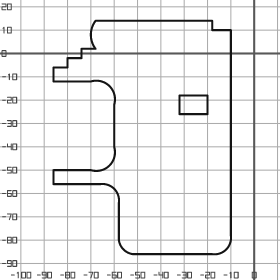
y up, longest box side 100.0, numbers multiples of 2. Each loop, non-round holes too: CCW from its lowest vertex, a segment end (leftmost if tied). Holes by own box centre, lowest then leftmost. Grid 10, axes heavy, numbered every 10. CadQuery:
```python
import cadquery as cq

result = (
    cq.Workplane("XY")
    .moveTo(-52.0, -86.0)
    .lineTo(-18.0, -86.0)
    .threePointArc((-12.0, -84.0), (-10.0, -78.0))
    .lineTo(-10.0, 10.0)
    .lineTo(-18.0, 10.0)
    .lineTo(-18.0, 14.0)
    .lineTo(-68.0, 14.0)
    .threePointArc((-70.0, 8.0), (-68.0, 2.0))
    .lineTo(-74.0, 2.0)
    .lineTo(-74.0, -2.0)
    .lineTo(-80.0, -2.0)
    .lineTo(-80.0, -6.0)
    .lineTo(-86.0, -6.0)
    .lineTo(-86.0, -12.0)
    .lineTo(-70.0, -12.0)
    .threePointArc((-62.0, -14.0), (-60.0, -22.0))
    .lineTo(-60.0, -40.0)
    .threePointArc((-62.0, -48.0), (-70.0, -50.0))
    .lineTo(-86.0, -50.0)
    .lineTo(-86.0, -56.0)
    .lineTo(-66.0, -56.0)
    .threePointArc((-60.0, -58.0), (-58.0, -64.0))
    .lineTo(-58.0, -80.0)
    .threePointArc((-56.0, -84.0), (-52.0, -86.0))
    .close()
    .moveTo(-32.0, -26.0)
    .lineTo(-20.0, -26.0)
    .lineTo(-20.0, -18.0)
    .lineTo(-32.0, -18.0)
    .close()
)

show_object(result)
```